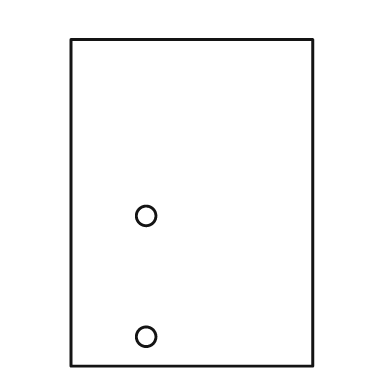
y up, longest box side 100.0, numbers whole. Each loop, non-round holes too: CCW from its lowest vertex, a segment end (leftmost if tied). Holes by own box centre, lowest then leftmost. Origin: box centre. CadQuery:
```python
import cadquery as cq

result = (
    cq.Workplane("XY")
    .moveTo(-37.0, -50.0)
    .lineTo(37.0, -50.0)
    .lineTo(37.0, 50.0)
    .lineTo(-37.0, 50.0)
    .close()
    .moveTo(-14.0, -41.0)
    .circle(3.0)
    .moveTo(-14.0, -4.0)
    .circle(3.0)
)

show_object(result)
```